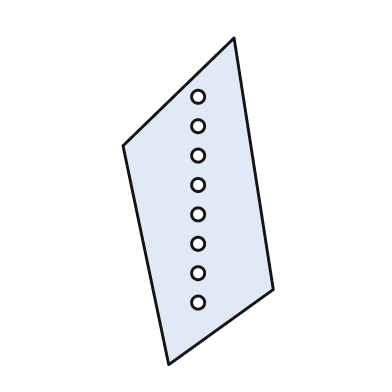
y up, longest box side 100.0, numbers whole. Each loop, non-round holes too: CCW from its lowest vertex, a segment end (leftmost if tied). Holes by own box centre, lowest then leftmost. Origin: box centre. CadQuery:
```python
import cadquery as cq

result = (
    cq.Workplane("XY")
    .moveTo(-9.0, -50.0)
    .lineTo(23.0, -27.0)
    .lineTo(11.0, 50.0)
    .lineTo(-23.0, 17.0)
    .close()
    .moveTo(0.0, -31.0)
    .circle(2.0)
    .moveTo(0.0, -22.0)
    .circle(2.0)
    .moveTo(0.0, -13.0)
    .circle(2.0)
    .moveTo(0.0, -4.0)
    .circle(2.0)
    .moveTo(0.0, 5.0)
    .circle(2.0)
    .moveTo(0.0, 14.0)
    .circle(2.0)
    .moveTo(0.0, 23.0)
    .circle(2.0)
    .moveTo(0.0, 32.0)
    .circle(2.0)
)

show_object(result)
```